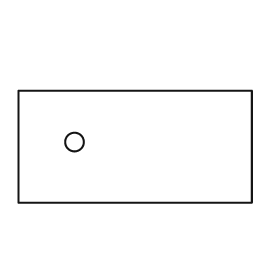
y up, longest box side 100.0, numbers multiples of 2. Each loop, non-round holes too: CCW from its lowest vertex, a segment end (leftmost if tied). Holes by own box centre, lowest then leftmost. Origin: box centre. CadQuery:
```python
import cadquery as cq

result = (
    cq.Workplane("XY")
    .moveTo(-50.0, -24.0)
    .lineTo(50.0, -24.0)
    .lineTo(50.0, 24.0)
    .lineTo(-50.0, 24.0)
    .close()
    .moveTo(-26.0, 2.0)
    .circle(4.0)
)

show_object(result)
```